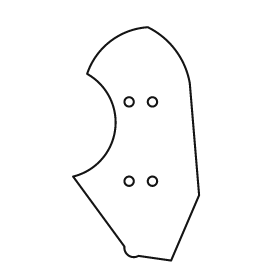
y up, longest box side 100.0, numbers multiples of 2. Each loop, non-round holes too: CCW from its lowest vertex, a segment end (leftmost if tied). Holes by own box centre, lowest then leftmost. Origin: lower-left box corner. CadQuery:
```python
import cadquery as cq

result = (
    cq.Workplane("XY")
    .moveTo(42.0, 0.0)
    .lineTo(54.0, 28.0)
    .lineTo(50.0, 76.0)
    .threePointArc((44.0, 90.0), (32.0, 100.0))
    .threePointArc((16.0, 94.0), (6.0, 80.0))
    .threePointArc((18.0, 56.0), (0.0, 36.0))
    .lineTo(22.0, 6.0)
    .threePointArc((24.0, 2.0), (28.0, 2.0))
    .close()
    .moveTo(24.0, 34.0)
    .circle(2.0)
    .moveTo(34.0, 34.0)
    .circle(2.0)
    .moveTo(24.0, 68.0)
    .circle(2.0)
    .moveTo(34.0, 68.0)
    .circle(2.0)
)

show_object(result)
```